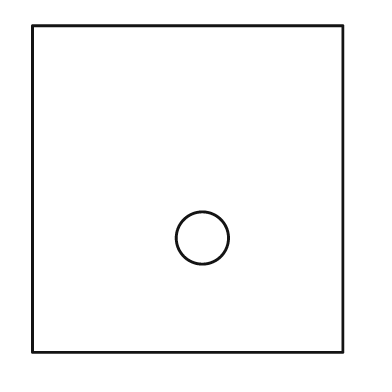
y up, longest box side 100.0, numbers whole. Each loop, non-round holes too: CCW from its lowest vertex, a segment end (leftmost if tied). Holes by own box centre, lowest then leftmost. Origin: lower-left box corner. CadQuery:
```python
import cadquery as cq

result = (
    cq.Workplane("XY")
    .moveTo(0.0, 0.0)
    .lineTo(95.0, 0.0)
    .lineTo(95.0, 100.0)
    .lineTo(0.0, 100.0)
    .close()
    .moveTo(52.0, 35.0)
    .circle(8.0)
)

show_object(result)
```